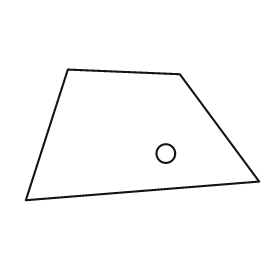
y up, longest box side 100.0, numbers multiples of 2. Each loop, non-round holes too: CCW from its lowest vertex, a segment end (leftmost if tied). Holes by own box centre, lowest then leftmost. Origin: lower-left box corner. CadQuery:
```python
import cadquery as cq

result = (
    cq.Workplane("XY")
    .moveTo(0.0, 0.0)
    .lineTo(100.0, 8.0)
    .lineTo(66.0, 54.0)
    .lineTo(18.0, 56.0)
    .close()
    .moveTo(60.0, 20.0)
    .circle(4.0)
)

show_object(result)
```